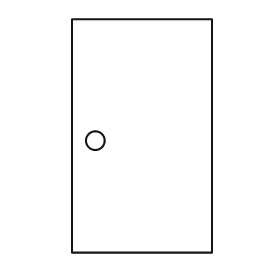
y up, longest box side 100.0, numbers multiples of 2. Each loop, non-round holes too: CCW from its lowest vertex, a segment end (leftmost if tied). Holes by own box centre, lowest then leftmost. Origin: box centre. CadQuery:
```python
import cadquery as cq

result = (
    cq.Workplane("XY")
    .moveTo(-30.0, -50.0)
    .lineTo(30.0, -50.0)
    .lineTo(30.0, 50.0)
    .lineTo(-30.0, 50.0)
    .close()
    .moveTo(-20.0, -2.0)
    .circle(4.0)
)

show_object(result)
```